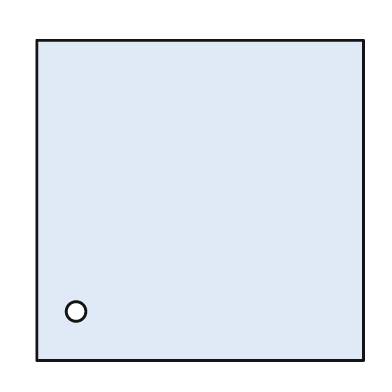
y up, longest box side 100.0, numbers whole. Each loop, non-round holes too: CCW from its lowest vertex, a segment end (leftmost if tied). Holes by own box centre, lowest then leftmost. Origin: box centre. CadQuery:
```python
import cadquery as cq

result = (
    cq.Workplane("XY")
    .moveTo(-50.0, -49.0)
    .lineTo(50.0, -49.0)
    .lineTo(50.0, 49.0)
    .lineTo(-50.0, 49.0)
    .close()
    .moveTo(-38.0, -34.0)
    .circle(3.0)
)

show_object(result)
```